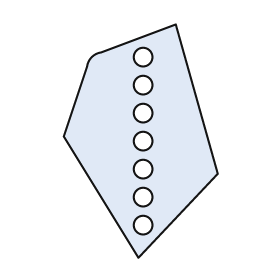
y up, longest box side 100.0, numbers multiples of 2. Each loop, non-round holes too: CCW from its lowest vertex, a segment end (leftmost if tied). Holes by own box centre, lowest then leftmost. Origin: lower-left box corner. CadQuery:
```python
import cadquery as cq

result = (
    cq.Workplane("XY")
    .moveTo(32.0, 0.0)
    .lineTo(66.0, 36.0)
    .lineTo(48.0, 100.0)
    .lineTo(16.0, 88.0)
    .threePointArc((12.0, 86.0), (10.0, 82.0))
    .lineTo(0.0, 52.0)
    .close()
    .moveTo(34.0, 14.0)
    .circle(4.0)
    .moveTo(34.0, 26.0)
    .circle(4.0)
    .moveTo(34.0, 38.0)
    .circle(4.0)
    .moveTo(34.0, 50.0)
    .circle(4.0)
    .moveTo(34.0, 62.0)
    .circle(4.0)
    .moveTo(34.0, 74.0)
    .circle(4.0)
    .moveTo(34.0, 86.0)
    .circle(4.0)
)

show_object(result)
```